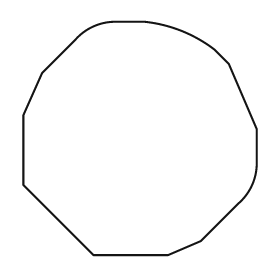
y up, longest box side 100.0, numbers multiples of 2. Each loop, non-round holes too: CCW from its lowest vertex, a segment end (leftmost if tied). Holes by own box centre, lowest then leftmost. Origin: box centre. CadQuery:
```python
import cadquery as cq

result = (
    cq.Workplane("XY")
    .moveTo(-20.0, -50.0)
    .lineTo(12.0, -50.0)
    .lineTo(26.0, -44.0)
    .lineTo(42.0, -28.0)
    .threePointArc((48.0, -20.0), (50.0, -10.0))
    .lineTo(50.0, 4.0)
    .lineTo(38.0, 32.0)
    .lineTo(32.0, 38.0)
    .threePointArc((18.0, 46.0), (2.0, 50.0))
    .lineTo(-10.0, 50.0)
    .threePointArc((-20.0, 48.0), (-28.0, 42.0))
    .lineTo(-42.0, 28.0)
    .lineTo(-50.0, 10.0)
    .lineTo(-50.0, -20.0)
    .close()
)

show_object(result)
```